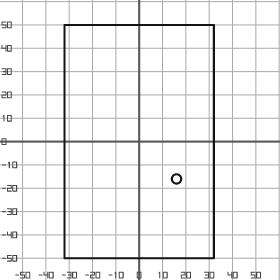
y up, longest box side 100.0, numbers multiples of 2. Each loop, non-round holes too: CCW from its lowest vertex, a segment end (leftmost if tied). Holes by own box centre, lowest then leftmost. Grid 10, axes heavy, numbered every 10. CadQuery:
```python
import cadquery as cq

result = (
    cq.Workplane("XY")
    .moveTo(-32.0, -50.0)
    .lineTo(32.0, -50.0)
    .lineTo(32.0, 50.0)
    .lineTo(-32.0, 50.0)
    .close()
    .moveTo(16.0, -16.0)
    .circle(2.0)
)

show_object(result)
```